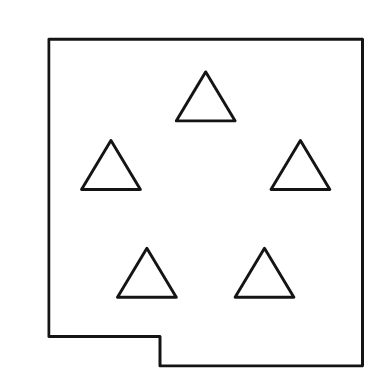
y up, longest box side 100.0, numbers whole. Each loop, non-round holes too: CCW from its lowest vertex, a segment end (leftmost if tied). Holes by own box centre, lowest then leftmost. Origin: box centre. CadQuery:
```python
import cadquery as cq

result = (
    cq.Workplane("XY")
    .moveTo(-14.0, -50.0)
    .lineTo(48.0, -50.0)
    .lineTo(48.0, 50.0)
    .lineTo(-48.0, 50.0)
    .lineTo(-48.0, -41.0)
    .lineTo(-14.0, -41.0)
    .close()
    .moveTo(-27.0, -29.0)
    .lineTo(-9.0, -29.0)
    .lineTo(-18.0, -14.0)
    .close()
    .moveTo(9.0, -29.0)
    .lineTo(27.0, -29.0)
    .lineTo(18.0, -14.0)
    .close()
    .moveTo(-38.0, 4.0)
    .lineTo(-20.0, 4.0)
    .lineTo(-29.0, 19.0)
    .close()
    .moveTo(20.0, 4.0)
    .lineTo(38.0, 4.0)
    .lineTo(29.0, 19.0)
    .close()
    .moveTo(-9.0, 25.0)
    .lineTo(9.0, 25.0)
    .lineTo(0.0, 40.0)
    .close()
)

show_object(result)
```